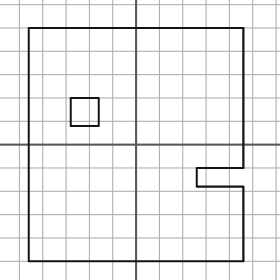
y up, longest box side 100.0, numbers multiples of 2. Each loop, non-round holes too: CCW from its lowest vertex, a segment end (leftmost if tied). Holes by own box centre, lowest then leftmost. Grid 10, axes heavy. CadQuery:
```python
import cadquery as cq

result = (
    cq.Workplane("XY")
    .moveTo(-46.0, -50.0)
    .lineTo(46.0, -50.0)
    .lineTo(46.0, -18.0)
    .lineTo(26.0, -18.0)
    .lineTo(26.0, -10.0)
    .lineTo(46.0, -10.0)
    .lineTo(46.0, 50.0)
    .lineTo(-46.0, 50.0)
    .close()
    .moveTo(-28.0, 8.0)
    .lineTo(-16.0, 8.0)
    .lineTo(-16.0, 20.0)
    .lineTo(-28.0, 20.0)
    .close()
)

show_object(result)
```